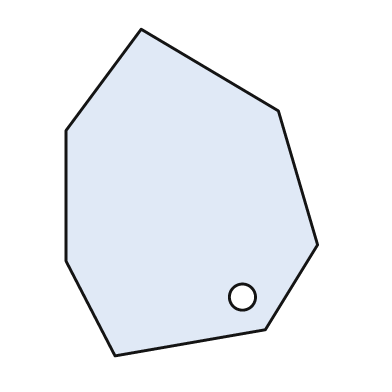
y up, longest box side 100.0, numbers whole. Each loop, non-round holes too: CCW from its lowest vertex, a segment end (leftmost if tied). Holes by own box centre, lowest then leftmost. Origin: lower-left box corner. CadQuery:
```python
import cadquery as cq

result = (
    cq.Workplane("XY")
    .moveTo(15.0, 0.0)
    .lineTo(61.0, 8.0)
    .lineTo(77.0, 34.0)
    .lineTo(65.0, 75.0)
    .lineTo(23.0, 100.0)
    .lineTo(0.0, 69.0)
    .lineTo(0.0, 29.0)
    .close()
    .moveTo(54.0, 18.0)
    .circle(4.0)
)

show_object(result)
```